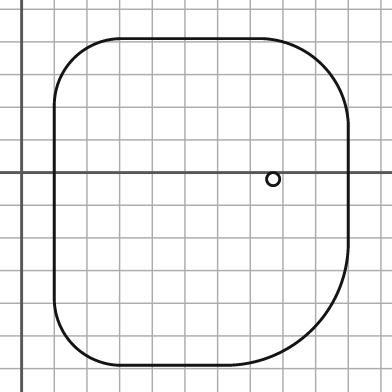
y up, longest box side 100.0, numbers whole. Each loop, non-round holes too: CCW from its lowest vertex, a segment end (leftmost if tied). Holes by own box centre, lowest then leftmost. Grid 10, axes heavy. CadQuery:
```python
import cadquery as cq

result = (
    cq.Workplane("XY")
    .moveTo(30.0, -59.0)
    .lineTo(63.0, -59.0)
    .threePointArc((89.0, -48.0), (100.0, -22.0))
    .lineTo(100.0, 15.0)
    .threePointArc((92.0, 33.0), (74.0, 41.0))
    .lineTo(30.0, 41.0)
    .threePointArc((16.0, 35.0), (10.0, 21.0))
    .lineTo(10.0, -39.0)
    .threePointArc((16.0, -53.0), (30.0, -59.0))
    .close()
    .moveTo(77.0, -2.0)
    .circle(2.0)
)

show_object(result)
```